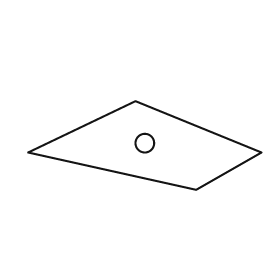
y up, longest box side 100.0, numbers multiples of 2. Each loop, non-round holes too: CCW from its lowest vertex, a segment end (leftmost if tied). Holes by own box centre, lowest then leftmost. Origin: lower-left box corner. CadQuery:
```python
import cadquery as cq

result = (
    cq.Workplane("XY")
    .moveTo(72.0, 0.0)
    .lineTo(100.0, 16.0)
    .lineTo(46.0, 38.0)
    .lineTo(0.0, 16.0)
    .close()
    .moveTo(50.0, 20.0)
    .circle(4.0)
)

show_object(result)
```